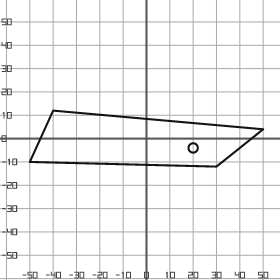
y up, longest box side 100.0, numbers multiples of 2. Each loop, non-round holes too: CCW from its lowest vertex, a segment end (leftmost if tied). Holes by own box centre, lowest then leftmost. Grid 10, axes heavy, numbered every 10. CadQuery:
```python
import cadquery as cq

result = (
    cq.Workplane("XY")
    .moveTo(30.0, -12.0)
    .lineTo(50.0, 4.0)
    .lineTo(-40.0, 12.0)
    .lineTo(-50.0, -10.0)
    .close()
    .moveTo(20.0, -4.0)
    .circle(2.0)
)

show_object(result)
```